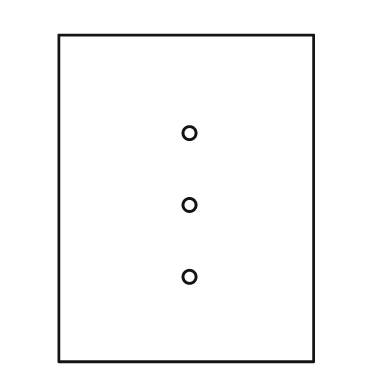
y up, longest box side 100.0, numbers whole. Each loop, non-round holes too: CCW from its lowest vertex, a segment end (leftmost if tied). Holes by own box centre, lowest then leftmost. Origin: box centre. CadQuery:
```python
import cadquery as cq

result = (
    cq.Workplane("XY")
    .moveTo(-39.0, -50.0)
    .lineTo(39.0, -50.0)
    .lineTo(39.0, 50.0)
    .lineTo(-39.0, 50.0)
    .close()
    .moveTo(1.0, -24.0)
    .circle(2.0)
    .moveTo(1.0, -2.0)
    .circle(2.0)
    .moveTo(1.0, 20.0)
    .circle(2.0)
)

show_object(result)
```